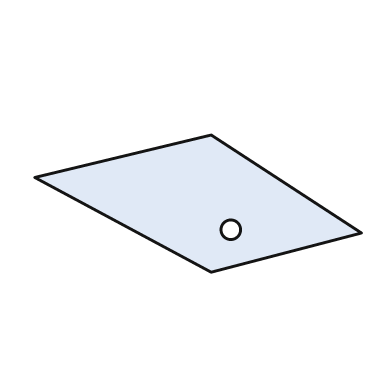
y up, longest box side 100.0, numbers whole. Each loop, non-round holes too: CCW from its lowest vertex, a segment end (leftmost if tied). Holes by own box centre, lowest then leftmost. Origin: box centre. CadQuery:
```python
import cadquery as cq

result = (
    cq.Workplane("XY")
    .moveTo(4.0, -21.0)
    .lineTo(50.0, -9.0)
    .lineTo(4.0, 21.0)
    .lineTo(-50.0, 8.0)
    .close()
    .moveTo(10.0, -8.0)
    .circle(3.0)
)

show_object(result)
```